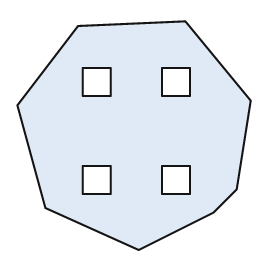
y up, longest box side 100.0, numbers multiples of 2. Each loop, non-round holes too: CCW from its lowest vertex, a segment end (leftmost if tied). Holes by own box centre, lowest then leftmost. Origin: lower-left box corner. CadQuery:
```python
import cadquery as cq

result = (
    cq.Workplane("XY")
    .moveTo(52.0, 0.0)
    .lineTo(84.0, 16.0)
    .lineTo(94.0, 26.0)
    .lineTo(100.0, 64.0)
    .lineTo(72.0, 98.0)
    .lineTo(26.0, 96.0)
    .lineTo(0.0, 62.0)
    .lineTo(12.0, 18.0)
    .close()
    .moveTo(28.0, 24.0)
    .lineTo(40.0, 24.0)
    .lineTo(40.0, 36.0)
    .lineTo(28.0, 36.0)
    .close()
    .moveTo(62.0, 24.0)
    .lineTo(74.0, 24.0)
    .lineTo(74.0, 36.0)
    .lineTo(62.0, 36.0)
    .close()
    .moveTo(28.0, 66.0)
    .lineTo(40.0, 66.0)
    .lineTo(40.0, 78.0)
    .lineTo(28.0, 78.0)
    .close()
    .moveTo(62.0, 66.0)
    .lineTo(74.0, 66.0)
    .lineTo(74.0, 78.0)
    .lineTo(62.0, 78.0)
    .close()
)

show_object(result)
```